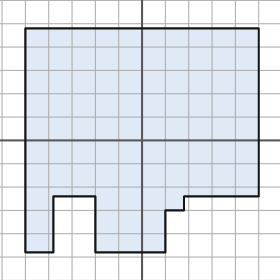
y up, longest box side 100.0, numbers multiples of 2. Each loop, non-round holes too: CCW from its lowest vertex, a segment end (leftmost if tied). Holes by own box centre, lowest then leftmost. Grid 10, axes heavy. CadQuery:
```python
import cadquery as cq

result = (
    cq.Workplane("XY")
    .moveTo(-50.0, -48.0)
    .lineTo(-38.0, -48.0)
    .lineTo(-38.0, -24.0)
    .lineTo(-20.0, -24.0)
    .lineTo(-20.0, -48.0)
    .lineTo(10.0, -48.0)
    .lineTo(10.0, -30.0)
    .lineTo(18.0, -30.0)
    .lineTo(18.0, -24.0)
    .lineTo(50.0, -24.0)
    .lineTo(50.0, 48.0)
    .lineTo(-50.0, 48.0)
    .close()
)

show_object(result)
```